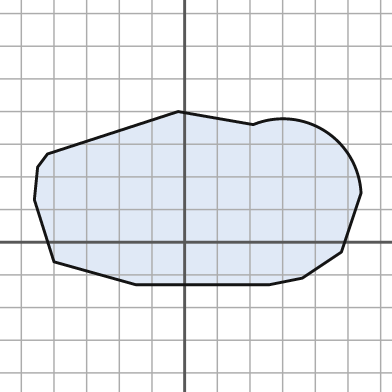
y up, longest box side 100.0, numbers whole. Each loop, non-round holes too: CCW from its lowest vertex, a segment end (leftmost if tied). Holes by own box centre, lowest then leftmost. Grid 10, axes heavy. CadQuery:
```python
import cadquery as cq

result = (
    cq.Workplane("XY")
    .moveTo(-15.0, -13.0)
    .lineTo(26.0, -13.0)
    .lineTo(36.0, -11.0)
    .lineTo(48.0, -3.0)
    .lineTo(54.0, 15.0)
    .threePointArc((43.0, 34.0), (21.0, 36.0))
    .lineTo(-2.0, 40.0)
    .lineTo(-42.0, 27.0)
    .lineTo(-45.0, 23.0)
    .lineTo(-46.0, 13.0)
    .lineTo(-40.0, -6.0)
    .close()
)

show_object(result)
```